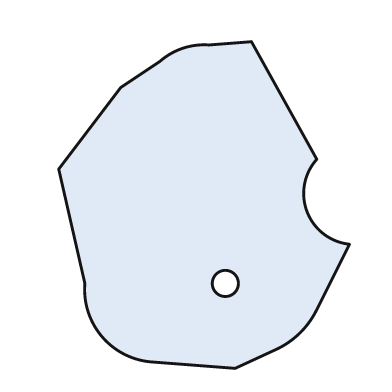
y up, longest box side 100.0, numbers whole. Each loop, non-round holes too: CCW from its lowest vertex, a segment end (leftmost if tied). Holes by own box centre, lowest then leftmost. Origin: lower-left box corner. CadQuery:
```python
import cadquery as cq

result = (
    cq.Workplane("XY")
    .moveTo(54.0, 0.0)
    .lineTo(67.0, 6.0)
    .threePointArc((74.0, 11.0), (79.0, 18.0))
    .lineTo(89.0, 38.0)
    .threePointArc((76.0, 48.0), (79.0, 64.0))
    .lineTo(59.0, 100.0)
    .lineTo(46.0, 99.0)
    .threePointArc((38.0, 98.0), (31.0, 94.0))
    .lineTo(19.0, 86.0)
    .lineTo(0.0, 61.0)
    .lineTo(8.0, 26.0)
    .threePointArc((13.0, 10.0), (28.0, 2.0))
    .close()
    .moveTo(51.0, 26.0)
    .circle(4.0)
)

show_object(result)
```